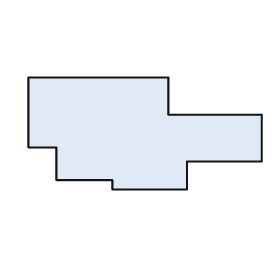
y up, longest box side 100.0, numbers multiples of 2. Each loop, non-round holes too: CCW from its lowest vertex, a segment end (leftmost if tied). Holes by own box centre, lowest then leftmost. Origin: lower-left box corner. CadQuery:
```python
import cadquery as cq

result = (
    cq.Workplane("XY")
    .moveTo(36.0, 0.0)
    .lineTo(68.0, 0.0)
    .lineTo(68.0, 12.0)
    .lineTo(100.0, 12.0)
    .lineTo(100.0, 32.0)
    .lineTo(60.0, 32.0)
    .lineTo(60.0, 48.0)
    .lineTo(0.0, 48.0)
    .lineTo(0.0, 18.0)
    .lineTo(12.0, 18.0)
    .lineTo(12.0, 4.0)
    .lineTo(36.0, 4.0)
    .close()
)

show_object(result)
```